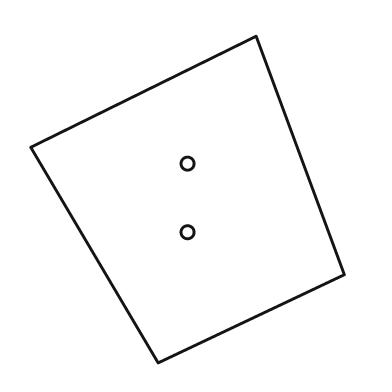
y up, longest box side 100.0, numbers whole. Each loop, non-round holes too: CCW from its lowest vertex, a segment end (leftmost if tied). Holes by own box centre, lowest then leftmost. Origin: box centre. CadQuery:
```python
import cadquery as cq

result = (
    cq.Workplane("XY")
    .moveTo(-9.0, -50.0)
    .lineTo(48.0, -23.0)
    .lineTo(21.0, 50.0)
    .lineTo(-48.0, 16.0)
    .close()
    .moveTo(0.0, -10.0)
    .circle(2.0)
    .moveTo(0.0, 11.0)
    .circle(2.0)
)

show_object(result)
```